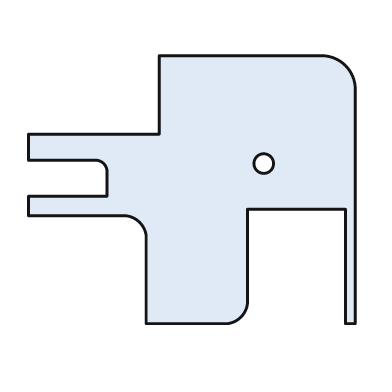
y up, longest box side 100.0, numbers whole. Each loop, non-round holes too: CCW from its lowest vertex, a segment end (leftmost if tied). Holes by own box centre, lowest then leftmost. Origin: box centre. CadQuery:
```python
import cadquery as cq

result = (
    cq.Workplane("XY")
    .moveTo(-14.0, -41.0)
    .lineTo(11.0, -41.0)
    .threePointArc((15.0, -39.0), (17.0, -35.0))
    .lineTo(17.0, -6.0)
    .lineTo(47.0, -6.0)
    .lineTo(47.0, -41.0)
    .lineTo(50.0, -41.0)
    .lineTo(50.0, 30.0)
    .threePointArc((47.0, 38.0), (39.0, 41.0))
    .lineTo(-10.0, 41.0)
    .lineTo(-10.0, 17.0)
    .lineTo(-50.0, 17.0)
    .lineTo(-50.0, 9.0)
    .lineTo(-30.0, 9.0)
    .threePointArc((-27.0, 8.0), (-26.0, 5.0))
    .lineTo(-26.0, -2.0)
    .lineTo(-50.0, -2.0)
    .lineTo(-50.0, -8.0)
    .lineTo(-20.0, -8.0)
    .threePointArc((-16.0, -10.0), (-14.0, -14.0))
    .close()
    .moveTo(22.0, 8.0)
    .circle(3.0)
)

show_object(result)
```